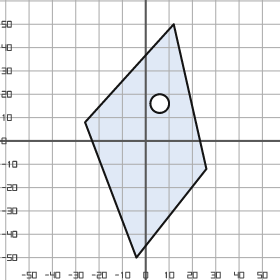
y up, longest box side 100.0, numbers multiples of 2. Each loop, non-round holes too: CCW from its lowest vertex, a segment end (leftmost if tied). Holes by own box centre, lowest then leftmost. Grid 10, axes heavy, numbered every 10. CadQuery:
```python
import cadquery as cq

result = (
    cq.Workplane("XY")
    .moveTo(-4.0, -50.0)
    .lineTo(26.0, -12.0)
    .lineTo(12.0, 50.0)
    .lineTo(-26.0, 8.0)
    .close()
    .moveTo(6.0, 16.0)
    .circle(4.0)
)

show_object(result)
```